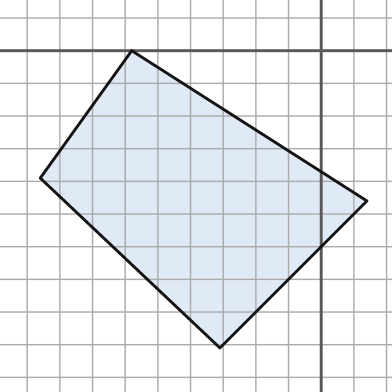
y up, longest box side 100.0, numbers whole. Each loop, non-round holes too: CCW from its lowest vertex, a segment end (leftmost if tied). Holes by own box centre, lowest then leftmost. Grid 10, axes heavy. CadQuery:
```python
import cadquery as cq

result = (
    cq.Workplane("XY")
    .moveTo(-31.0, -91.0)
    .lineTo(14.0, -46.0)
    .lineTo(-58.0, 0.0)
    .lineTo(-86.0, -39.0)
    .close()
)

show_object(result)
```